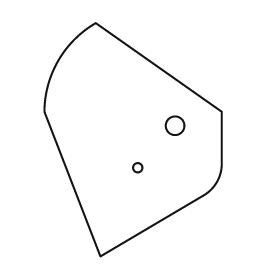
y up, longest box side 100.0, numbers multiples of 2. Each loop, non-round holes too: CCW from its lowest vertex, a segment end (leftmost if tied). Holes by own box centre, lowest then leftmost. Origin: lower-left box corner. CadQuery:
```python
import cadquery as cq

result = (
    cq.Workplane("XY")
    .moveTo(24.0, 0.0)
    .lineTo(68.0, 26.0)
    .threePointArc((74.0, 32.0), (76.0, 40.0))
    .lineTo(76.0, 62.0)
    .lineTo(22.0, 100.0)
    .threePointArc((6.0, 84.0), (0.0, 62.0))
    .close()
    .moveTo(40.0, 38.0)
    .circle(2.0)
    .moveTo(56.0, 56.0)
    .circle(4.0)
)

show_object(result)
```